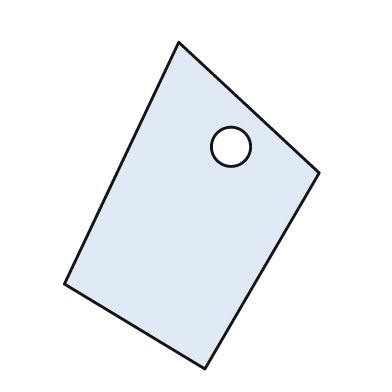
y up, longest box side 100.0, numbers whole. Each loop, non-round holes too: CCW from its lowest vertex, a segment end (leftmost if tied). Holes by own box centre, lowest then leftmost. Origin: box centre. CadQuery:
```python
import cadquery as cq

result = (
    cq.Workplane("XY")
    .moveTo(4.0, -50.0)
    .lineTo(39.0, 10.0)
    .lineTo(-4.0, 50.0)
    .lineTo(-39.0, -24.0)
    .close()
    .moveTo(12.0, 18.0)
    .circle(6.0)
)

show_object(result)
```